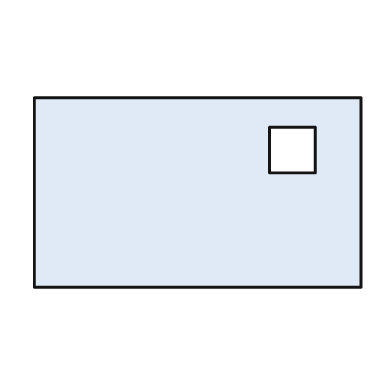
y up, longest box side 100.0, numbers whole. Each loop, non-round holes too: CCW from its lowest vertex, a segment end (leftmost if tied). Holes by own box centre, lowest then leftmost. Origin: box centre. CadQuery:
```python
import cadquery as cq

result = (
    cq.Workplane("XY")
    .moveTo(-50.0, -29.0)
    .lineTo(50.0, -29.0)
    .lineTo(50.0, 29.0)
    .lineTo(-50.0, 29.0)
    .close()
    .moveTo(22.0, 6.0)
    .lineTo(36.0, 6.0)
    .lineTo(36.0, 20.0)
    .lineTo(22.0, 20.0)
    .close()
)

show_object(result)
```